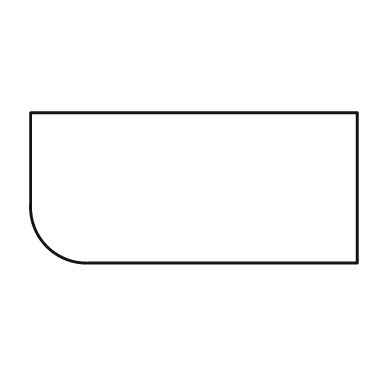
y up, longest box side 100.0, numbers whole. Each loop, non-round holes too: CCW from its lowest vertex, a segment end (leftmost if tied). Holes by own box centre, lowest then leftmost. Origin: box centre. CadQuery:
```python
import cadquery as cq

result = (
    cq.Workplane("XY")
    .moveTo(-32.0, -23.0)
    .lineTo(50.0, -23.0)
    .lineTo(50.0, 23.0)
    .lineTo(-50.0, 23.0)
    .lineTo(-50.0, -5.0)
    .threePointArc((-45.0, -18.0), (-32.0, -23.0))
    .close()
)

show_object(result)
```